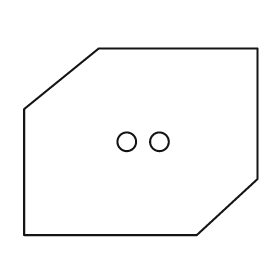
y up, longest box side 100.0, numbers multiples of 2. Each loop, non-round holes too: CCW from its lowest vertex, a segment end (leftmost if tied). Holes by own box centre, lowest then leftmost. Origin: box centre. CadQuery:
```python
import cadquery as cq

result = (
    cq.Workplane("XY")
    .moveTo(-50.0, -40.0)
    .lineTo(24.0, -40.0)
    .lineTo(50.0, -16.0)
    .lineTo(50.0, 40.0)
    .lineTo(-18.0, 40.0)
    .lineTo(-50.0, 14.0)
    .close()
    .moveTo(-6.0, 0.0)
    .circle(4.0)
    .moveTo(8.0, 0.0)
    .circle(4.0)
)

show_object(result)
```